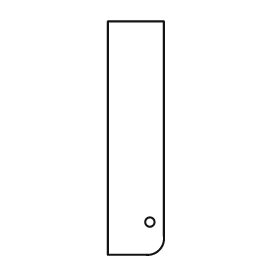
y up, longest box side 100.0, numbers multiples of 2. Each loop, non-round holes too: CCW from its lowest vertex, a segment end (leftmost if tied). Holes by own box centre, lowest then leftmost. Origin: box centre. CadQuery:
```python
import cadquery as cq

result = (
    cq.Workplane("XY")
    .moveTo(-12.0, -50.0)
    .lineTo(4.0, -50.0)
    .threePointArc((10.0, -48.0), (12.0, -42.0))
    .lineTo(12.0, 50.0)
    .lineTo(-12.0, 50.0)
    .close()
    .moveTo(6.0, -36.0)
    .circle(2.0)
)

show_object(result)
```